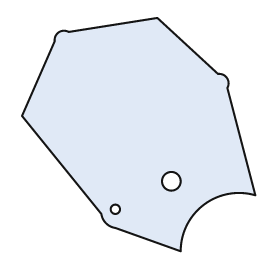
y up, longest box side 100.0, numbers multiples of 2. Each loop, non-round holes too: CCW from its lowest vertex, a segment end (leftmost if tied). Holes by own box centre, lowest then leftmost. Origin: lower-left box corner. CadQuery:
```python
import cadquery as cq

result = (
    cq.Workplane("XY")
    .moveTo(68.0, 0.0)
    .threePointArc((78.0, 20.0), (100.0, 24.0))
    .lineTo(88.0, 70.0)
    .threePointArc((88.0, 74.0), (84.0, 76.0))
    .lineTo(58.0, 100.0)
    .lineTo(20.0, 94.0)
    .threePointArc((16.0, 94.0), (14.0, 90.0))
    .lineTo(0.0, 58.0)
    .lineTo(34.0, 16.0)
    .threePointArc((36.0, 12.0), (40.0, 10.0))
    .close()
    .moveTo(40.0, 18.0)
    .circle(2.0)
    .moveTo(64.0, 30.0)
    .circle(4.0)
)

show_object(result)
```